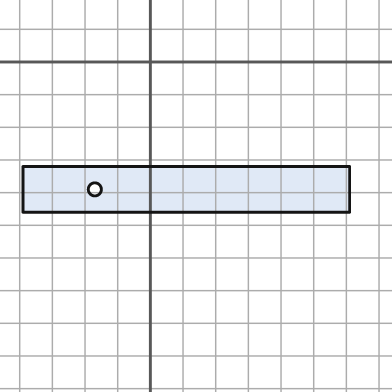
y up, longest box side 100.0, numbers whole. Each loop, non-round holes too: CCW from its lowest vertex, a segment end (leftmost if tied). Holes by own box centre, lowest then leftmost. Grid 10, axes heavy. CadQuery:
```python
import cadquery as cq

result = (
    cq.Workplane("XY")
    .moveTo(-39.0, -46.0)
    .lineTo(61.0, -46.0)
    .lineTo(61.0, -32.0)
    .lineTo(-39.0, -32.0)
    .close()
    .moveTo(-17.0, -39.0)
    .circle(2.0)
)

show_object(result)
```